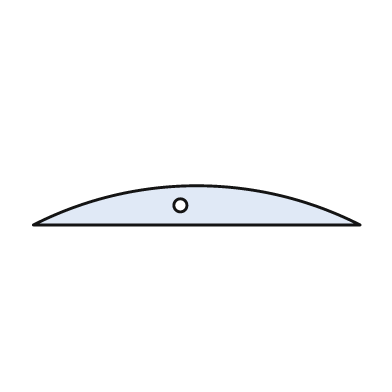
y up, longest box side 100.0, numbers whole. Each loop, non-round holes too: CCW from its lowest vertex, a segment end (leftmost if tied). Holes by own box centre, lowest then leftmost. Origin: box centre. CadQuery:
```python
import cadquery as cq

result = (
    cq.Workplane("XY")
    .moveTo(-50.0, -6.0)
    .lineTo(50.0, -6.0)
    .threePointArc((0.0, 6.0), (-50.0, -6.0))
    .close()
    .moveTo(-5.0, 0.0)
    .circle(2.0)
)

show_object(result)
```